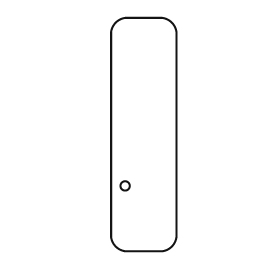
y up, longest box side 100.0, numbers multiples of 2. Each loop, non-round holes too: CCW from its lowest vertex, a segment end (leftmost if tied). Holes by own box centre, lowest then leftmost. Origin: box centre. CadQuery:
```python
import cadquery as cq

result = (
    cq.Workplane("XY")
    .moveTo(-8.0, -50.0)
    .lineTo(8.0, -50.0)
    .threePointArc((12.0, -48.0), (14.0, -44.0))
    .lineTo(14.0, 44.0)
    .threePointArc((12.0, 48.0), (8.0, 50.0))
    .lineTo(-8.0, 50.0)
    .threePointArc((-12.0, 48.0), (-14.0, 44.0))
    .lineTo(-14.0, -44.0)
    .threePointArc((-12.0, -48.0), (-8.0, -50.0))
    .close()
    .moveTo(-8.0, -22.0)
    .circle(2.0)
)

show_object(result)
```